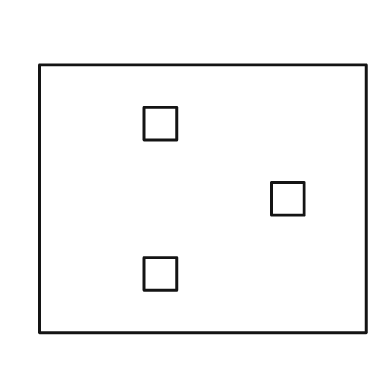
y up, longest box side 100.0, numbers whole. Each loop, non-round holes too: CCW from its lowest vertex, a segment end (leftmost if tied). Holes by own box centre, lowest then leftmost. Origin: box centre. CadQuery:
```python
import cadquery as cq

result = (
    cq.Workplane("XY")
    .moveTo(-50.0, -41.0)
    .lineTo(50.0, -41.0)
    .lineTo(50.0, 41.0)
    .lineTo(-50.0, 41.0)
    .close()
    .moveTo(-18.0, -28.0)
    .lineTo(-8.0, -28.0)
    .lineTo(-8.0, -18.0)
    .lineTo(-18.0, -18.0)
    .close()
    .moveTo(21.0, -5.0)
    .lineTo(31.0, -5.0)
    .lineTo(31.0, 5.0)
    .lineTo(21.0, 5.0)
    .close()
    .moveTo(-18.0, 18.0)
    .lineTo(-8.0, 18.0)
    .lineTo(-8.0, 28.0)
    .lineTo(-18.0, 28.0)
    .close()
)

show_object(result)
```